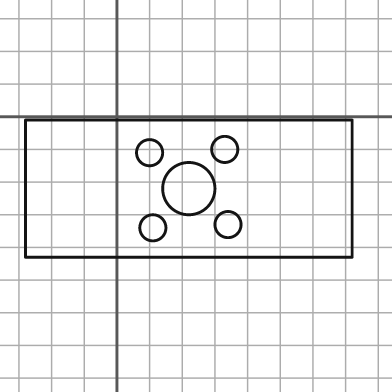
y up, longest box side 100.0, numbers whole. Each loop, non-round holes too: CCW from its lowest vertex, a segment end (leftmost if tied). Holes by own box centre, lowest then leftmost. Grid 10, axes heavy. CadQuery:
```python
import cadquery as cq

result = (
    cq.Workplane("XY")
    .moveTo(-28.0, -43.0)
    .lineTo(72.0, -43.0)
    .lineTo(72.0, -1.0)
    .lineTo(-28.0, -1.0)
    .close()
    .moveTo(11.0, -34.0)
    .circle(4.0)
    .moveTo(34.0, -33.0)
    .circle(4.0)
    .moveTo(22.0, -22.0)
    .circle(8.0)
    .moveTo(10.0, -11.0)
    .circle(4.0)
    .moveTo(33.0, -10.0)
    .circle(4.0)
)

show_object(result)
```